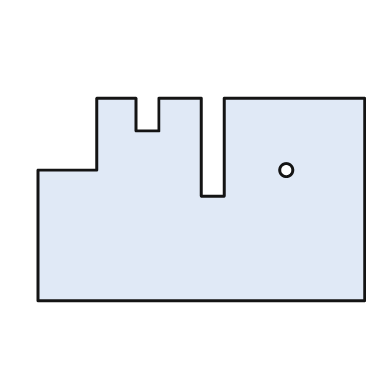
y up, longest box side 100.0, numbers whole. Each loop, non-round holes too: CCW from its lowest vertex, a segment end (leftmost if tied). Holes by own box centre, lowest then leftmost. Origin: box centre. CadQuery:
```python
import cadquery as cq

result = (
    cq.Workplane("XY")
    .moveTo(-50.0, -31.0)
    .lineTo(50.0, -31.0)
    .lineTo(50.0, 31.0)
    .lineTo(7.0, 31.0)
    .lineTo(7.0, 1.0)
    .lineTo(0.0, 1.0)
    .lineTo(0.0, 31.0)
    .lineTo(-13.0, 31.0)
    .lineTo(-13.0, 21.0)
    .lineTo(-20.0, 21.0)
    .lineTo(-20.0, 31.0)
    .lineTo(-32.0, 31.0)
    .lineTo(-32.0, 9.0)
    .lineTo(-50.0, 9.0)
    .close()
    .moveTo(26.0, 9.0)
    .circle(2.0)
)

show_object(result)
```